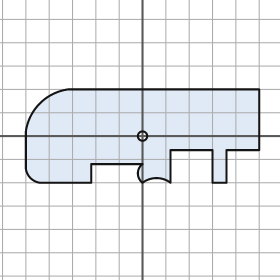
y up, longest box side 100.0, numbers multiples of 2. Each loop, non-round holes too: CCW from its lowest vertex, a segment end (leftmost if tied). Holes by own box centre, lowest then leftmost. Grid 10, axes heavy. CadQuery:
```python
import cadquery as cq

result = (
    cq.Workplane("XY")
    .moveTo(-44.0, -20.0)
    .lineTo(-22.0, -20.0)
    .lineTo(-22.0, -12.0)
    .lineTo(0.0, -12.0)
    .threePointArc((-2.0, -16.0), (0.0, -20.0))
    .threePointArc((6.0, -18.0), (12.0, -20.0))
    .lineTo(12.0, -6.0)
    .lineTo(30.0, -6.0)
    .lineTo(30.0, -20.0)
    .lineTo(36.0, -20.0)
    .lineTo(36.0, -6.0)
    .lineTo(50.0, -6.0)
    .lineTo(50.0, 20.0)
    .lineTo(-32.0, 20.0)
    .threePointArc((-44.0, 14.0), (-50.0, 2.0))
    .lineTo(-50.0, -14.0)
    .threePointArc((-48.0, -18.0), (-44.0, -20.0))
    .close()
    .moveTo(0.0, 0.0)
    .circle(2.0)
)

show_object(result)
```